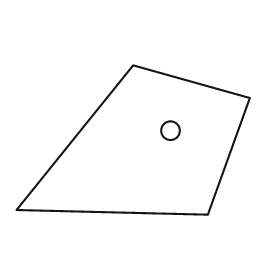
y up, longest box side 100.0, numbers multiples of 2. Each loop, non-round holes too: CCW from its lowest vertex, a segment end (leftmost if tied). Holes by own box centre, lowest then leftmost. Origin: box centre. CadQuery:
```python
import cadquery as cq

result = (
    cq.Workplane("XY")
    .moveTo(32.0, -32.0)
    .lineTo(50.0, 18.0)
    .lineTo(0.0, 32.0)
    .lineTo(-50.0, -30.0)
    .close()
    .moveTo(16.0, 4.0)
    .circle(4.0)
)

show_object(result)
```